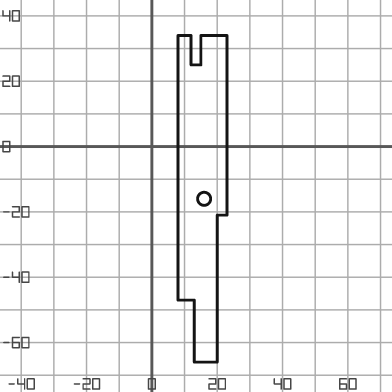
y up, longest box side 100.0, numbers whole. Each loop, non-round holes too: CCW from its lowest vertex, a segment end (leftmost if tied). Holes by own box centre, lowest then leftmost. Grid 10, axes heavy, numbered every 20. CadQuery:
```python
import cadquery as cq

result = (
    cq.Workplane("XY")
    .moveTo(13.0, -66.0)
    .lineTo(20.0, -66.0)
    .lineTo(20.0, -21.0)
    .lineTo(23.0, -21.0)
    .lineTo(23.0, 34.0)
    .lineTo(15.0, 34.0)
    .lineTo(15.0, 25.0)
    .lineTo(12.0, 25.0)
    .lineTo(12.0, 34.0)
    .lineTo(8.0, 34.0)
    .lineTo(8.0, -47.0)
    .lineTo(13.0, -47.0)
    .close()
    .moveTo(16.0, -16.0)
    .circle(2.0)
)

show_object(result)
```